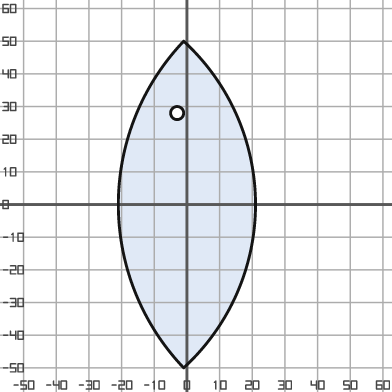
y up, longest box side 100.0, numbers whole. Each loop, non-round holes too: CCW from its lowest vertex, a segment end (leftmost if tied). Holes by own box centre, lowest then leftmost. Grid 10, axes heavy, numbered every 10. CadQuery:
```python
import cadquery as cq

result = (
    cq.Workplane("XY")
    .moveTo(-1.0, -50.0)
    .threePointArc((21.0, 0.0), (-1.0, 50.0))
    .threePointArc((-21.0, 0.0), (-1.0, -50.0))
    .close()
    .moveTo(-3.0, 28.0)
    .circle(2.0)
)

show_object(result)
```